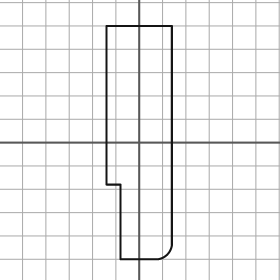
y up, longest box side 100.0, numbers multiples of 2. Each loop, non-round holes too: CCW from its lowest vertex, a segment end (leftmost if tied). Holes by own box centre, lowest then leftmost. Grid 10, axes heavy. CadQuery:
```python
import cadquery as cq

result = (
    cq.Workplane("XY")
    .moveTo(-8.0, -50.0)
    .lineTo(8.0, -50.0)
    .threePointArc((12.0, -48.0), (14.0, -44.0))
    .lineTo(14.0, 50.0)
    .lineTo(-14.0, 50.0)
    .lineTo(-14.0, -18.0)
    .lineTo(-8.0, -18.0)
    .close()
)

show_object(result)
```